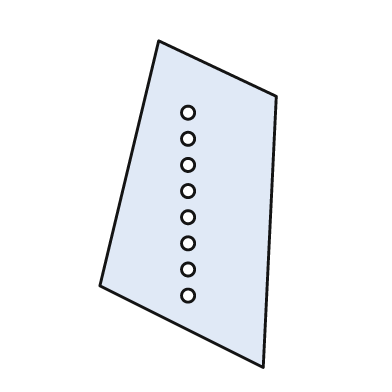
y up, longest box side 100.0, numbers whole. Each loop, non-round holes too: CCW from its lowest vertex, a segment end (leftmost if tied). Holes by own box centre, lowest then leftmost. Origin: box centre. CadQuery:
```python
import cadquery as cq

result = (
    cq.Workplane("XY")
    .moveTo(23.0, -50.0)
    .lineTo(27.0, 33.0)
    .lineTo(-9.0, 50.0)
    .lineTo(-27.0, -25.0)
    .close()
    .moveTo(0.0, -28.0)
    .circle(2.0)
    .moveTo(0.0, -20.0)
    .circle(2.0)
    .moveTo(0.0, -12.0)
    .circle(2.0)
    .moveTo(0.0, -4.0)
    .circle(2.0)
    .moveTo(0.0, 4.0)
    .circle(2.0)
    .moveTo(0.0, 12.0)
    .circle(2.0)
    .moveTo(0.0, 20.0)
    .circle(2.0)
    .moveTo(0.0, 28.0)
    .circle(2.0)
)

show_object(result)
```